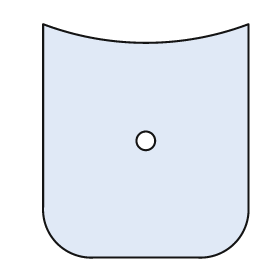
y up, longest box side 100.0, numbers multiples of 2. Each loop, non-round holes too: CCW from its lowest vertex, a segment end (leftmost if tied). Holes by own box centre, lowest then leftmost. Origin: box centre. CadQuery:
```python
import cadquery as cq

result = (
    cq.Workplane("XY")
    .moveTo(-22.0, -50.0)
    .lineTo(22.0, -50.0)
    .threePointArc((38.0, -44.0), (44.0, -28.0))
    .lineTo(44.0, 50.0)
    .threePointArc((0.0, 42.0), (-44.0, 50.0))
    .lineTo(-44.0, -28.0)
    .threePointArc((-38.0, -44.0), (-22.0, -50.0))
    .close()
    .moveTo(0.0, 0.0)
    .circle(4.0)
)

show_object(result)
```